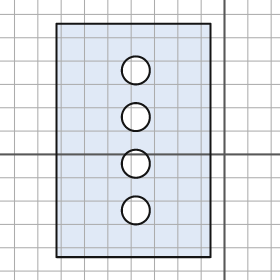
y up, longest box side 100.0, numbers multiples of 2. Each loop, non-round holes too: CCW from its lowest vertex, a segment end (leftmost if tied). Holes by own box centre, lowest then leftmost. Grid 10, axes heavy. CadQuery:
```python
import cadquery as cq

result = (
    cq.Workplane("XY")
    .moveTo(-72.0, -44.0)
    .lineTo(-6.0, -44.0)
    .lineTo(-6.0, 56.0)
    .lineTo(-72.0, 56.0)
    .close()
    .moveTo(-38.0, -24.0)
    .circle(6.0)
    .moveTo(-38.0, -4.0)
    .circle(6.0)
    .moveTo(-38.0, 16.0)
    .circle(6.0)
    .moveTo(-38.0, 36.0)
    .circle(6.0)
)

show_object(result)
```